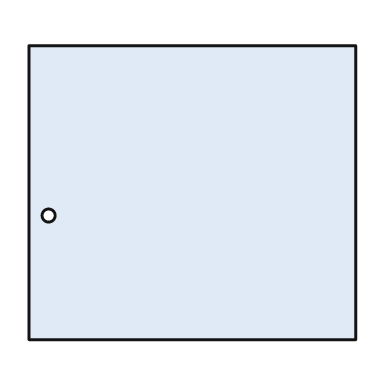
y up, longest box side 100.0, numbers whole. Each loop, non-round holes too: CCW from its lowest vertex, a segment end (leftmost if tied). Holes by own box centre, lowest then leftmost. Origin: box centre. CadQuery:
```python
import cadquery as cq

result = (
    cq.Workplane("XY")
    .moveTo(-50.0, -45.0)
    .lineTo(50.0, -45.0)
    .lineTo(50.0, 45.0)
    .lineTo(-50.0, 45.0)
    .close()
    .moveTo(-44.0, -7.0)
    .circle(2.0)
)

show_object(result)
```